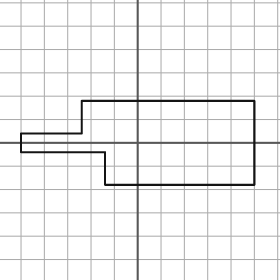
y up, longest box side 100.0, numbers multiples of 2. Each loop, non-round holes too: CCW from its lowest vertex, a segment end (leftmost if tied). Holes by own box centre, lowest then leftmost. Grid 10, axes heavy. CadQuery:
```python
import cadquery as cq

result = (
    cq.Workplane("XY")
    .moveTo(-14.0, -18.0)
    .lineTo(50.0, -18.0)
    .lineTo(50.0, 18.0)
    .lineTo(-24.0, 18.0)
    .lineTo(-24.0, 4.0)
    .lineTo(-50.0, 4.0)
    .lineTo(-50.0, -4.0)
    .lineTo(-14.0, -4.0)
    .close()
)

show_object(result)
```